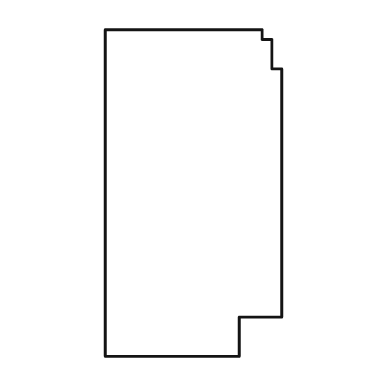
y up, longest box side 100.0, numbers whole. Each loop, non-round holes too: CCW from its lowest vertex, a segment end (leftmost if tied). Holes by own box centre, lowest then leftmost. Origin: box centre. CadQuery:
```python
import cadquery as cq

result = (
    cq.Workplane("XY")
    .moveTo(-27.0, -50.0)
    .lineTo(14.0, -50.0)
    .lineTo(14.0, -38.0)
    .lineTo(27.0, -38.0)
    .lineTo(27.0, 38.0)
    .lineTo(24.0, 38.0)
    .lineTo(24.0, 47.0)
    .lineTo(21.0, 47.0)
    .lineTo(21.0, 50.0)
    .lineTo(-27.0, 50.0)
    .close()
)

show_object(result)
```